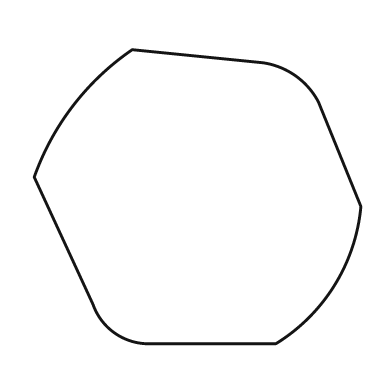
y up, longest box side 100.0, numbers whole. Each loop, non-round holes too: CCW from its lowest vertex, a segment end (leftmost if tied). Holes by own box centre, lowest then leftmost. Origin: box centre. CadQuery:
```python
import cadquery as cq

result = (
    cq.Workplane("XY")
    .moveTo(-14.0, -45.0)
    .lineTo(24.0, -45.0)
    .threePointArc((42.0, -27.0), (50.0, -3.0))
    .lineTo(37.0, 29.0)
    .threePointArc((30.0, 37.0), (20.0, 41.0))
    .lineTo(-20.0, 45.0)
    .threePointArc((-38.0, 28.0), (-50.0, 6.0))
    .lineTo(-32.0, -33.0)
    .threePointArc((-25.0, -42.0), (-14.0, -45.0))
    .close()
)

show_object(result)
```